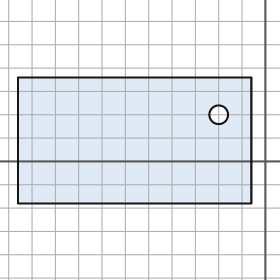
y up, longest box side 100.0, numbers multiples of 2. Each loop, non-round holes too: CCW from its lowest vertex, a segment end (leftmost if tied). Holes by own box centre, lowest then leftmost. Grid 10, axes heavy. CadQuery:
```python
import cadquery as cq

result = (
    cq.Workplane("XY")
    .moveTo(-106.0, -18.0)
    .lineTo(-6.0, -18.0)
    .lineTo(-6.0, 36.0)
    .lineTo(-106.0, 36.0)
    .close()
    .moveTo(-20.0, 20.0)
    .circle(4.0)
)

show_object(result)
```